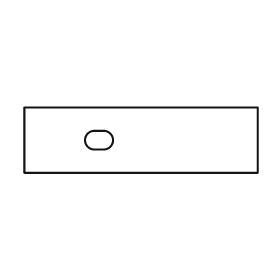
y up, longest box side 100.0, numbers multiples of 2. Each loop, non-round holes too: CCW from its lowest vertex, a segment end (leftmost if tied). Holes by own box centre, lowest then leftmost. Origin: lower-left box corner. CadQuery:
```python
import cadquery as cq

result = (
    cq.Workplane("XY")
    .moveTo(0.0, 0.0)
    .lineTo(100.0, 0.0)
    .lineTo(100.0, 28.0)
    .lineTo(0.0, 28.0)
    .close()
    .moveTo(30.0, 10.0)
    .lineTo(34.0, 10.0)
    .threePointArc((38.0, 14.0), (34.0, 18.0))
    .lineTo(30.0, 18.0)
    .threePointArc((26.0, 14.0), (30.0, 10.0))
    .close()
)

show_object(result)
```